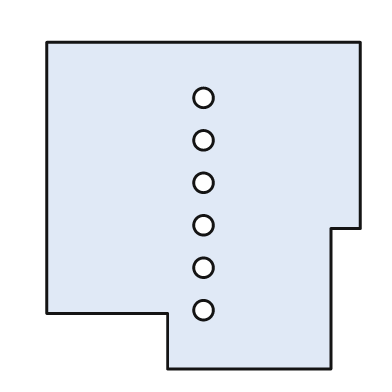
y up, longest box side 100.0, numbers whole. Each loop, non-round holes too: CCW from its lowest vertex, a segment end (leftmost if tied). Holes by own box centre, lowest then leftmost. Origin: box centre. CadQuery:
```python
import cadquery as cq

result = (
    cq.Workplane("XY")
    .moveTo(-11.0, -50.0)
    .lineTo(39.0, -50.0)
    .lineTo(39.0, -7.0)
    .lineTo(48.0, -7.0)
    .lineTo(48.0, 50.0)
    .lineTo(-48.0, 50.0)
    .lineTo(-48.0, -33.0)
    .lineTo(-11.0, -33.0)
    .close()
    .moveTo(0.0, -32.0)
    .circle(3.0)
    .moveTo(0.0, -19.0)
    .circle(3.0)
    .moveTo(0.0, -6.0)
    .circle(3.0)
    .moveTo(0.0, 7.0)
    .circle(3.0)
    .moveTo(0.0, 20.0)
    .circle(3.0)
    .moveTo(0.0, 33.0)
    .circle(3.0)
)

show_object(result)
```